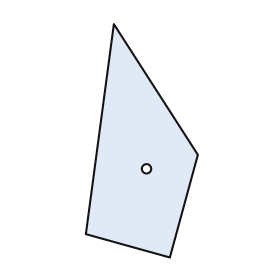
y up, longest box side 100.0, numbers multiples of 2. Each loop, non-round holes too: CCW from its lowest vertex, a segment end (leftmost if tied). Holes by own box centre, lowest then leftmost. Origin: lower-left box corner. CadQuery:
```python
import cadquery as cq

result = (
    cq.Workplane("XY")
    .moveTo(36.0, 0.0)
    .lineTo(48.0, 44.0)
    .lineTo(12.0, 100.0)
    .lineTo(0.0, 10.0)
    .close()
    .moveTo(26.0, 38.0)
    .circle(2.0)
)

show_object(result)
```